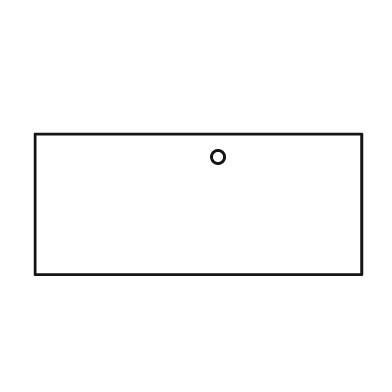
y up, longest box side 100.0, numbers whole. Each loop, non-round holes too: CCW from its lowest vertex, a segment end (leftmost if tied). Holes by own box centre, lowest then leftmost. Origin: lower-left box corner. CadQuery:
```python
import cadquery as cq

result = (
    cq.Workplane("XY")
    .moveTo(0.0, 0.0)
    .lineTo(100.0, 0.0)
    .lineTo(100.0, 43.0)
    .lineTo(0.0, 43.0)
    .close()
    .moveTo(56.0, 36.0)
    .circle(2.0)
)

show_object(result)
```